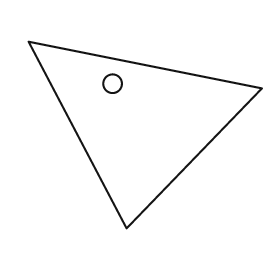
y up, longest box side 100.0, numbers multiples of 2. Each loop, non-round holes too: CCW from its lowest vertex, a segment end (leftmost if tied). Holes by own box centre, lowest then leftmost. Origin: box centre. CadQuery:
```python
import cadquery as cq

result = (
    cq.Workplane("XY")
    .moveTo(-8.0, -40.0)
    .lineTo(50.0, 20.0)
    .lineTo(-50.0, 40.0)
    .close()
    .moveTo(-14.0, 22.0)
    .circle(4.0)
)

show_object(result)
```